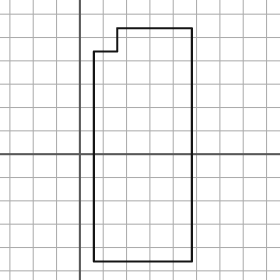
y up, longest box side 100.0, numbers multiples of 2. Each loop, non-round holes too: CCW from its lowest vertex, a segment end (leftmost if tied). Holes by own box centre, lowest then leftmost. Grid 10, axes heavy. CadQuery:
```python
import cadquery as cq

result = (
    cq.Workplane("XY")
    .moveTo(6.0, -46.0)
    .lineTo(48.0, -46.0)
    .lineTo(48.0, 54.0)
    .lineTo(16.0, 54.0)
    .lineTo(16.0, 44.0)
    .lineTo(6.0, 44.0)
    .close()
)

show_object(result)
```